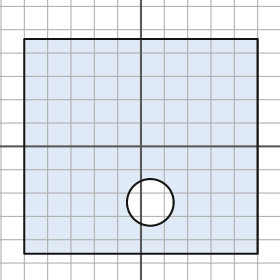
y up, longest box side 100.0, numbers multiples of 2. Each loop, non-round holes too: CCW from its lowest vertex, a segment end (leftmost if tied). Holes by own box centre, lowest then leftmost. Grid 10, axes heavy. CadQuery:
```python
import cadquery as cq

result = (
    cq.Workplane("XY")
    .moveTo(-50.0, -46.0)
    .lineTo(50.0, -46.0)
    .lineTo(50.0, 46.0)
    .lineTo(-50.0, 46.0)
    .close()
    .moveTo(4.0, -24.0)
    .circle(10.0)
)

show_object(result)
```